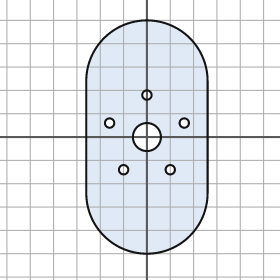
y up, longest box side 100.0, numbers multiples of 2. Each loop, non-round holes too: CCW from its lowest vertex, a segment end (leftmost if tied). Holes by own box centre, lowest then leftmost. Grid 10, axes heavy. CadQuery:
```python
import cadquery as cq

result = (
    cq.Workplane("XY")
    .moveTo(-26.0, -24.0)
    .threePointArc((0.0, -50.0), (26.0, -24.0))
    .lineTo(26.0, 24.0)
    .threePointArc((0.0, 50.0), (-26.0, 24.0))
    .close()
    .moveTo(-10.0, -14.0)
    .circle(2.0)
    .moveTo(10.0, -14.0)
    .circle(2.0)
    .moveTo(0.0, 0.0)
    .circle(6.0)
    .moveTo(-16.0, 6.0)
    .circle(2.0)
    .moveTo(16.0, 6.0)
    .circle(2.0)
    .moveTo(0.0, 18.0)
    .circle(2.0)
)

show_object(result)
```